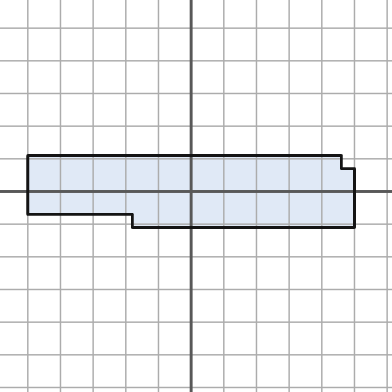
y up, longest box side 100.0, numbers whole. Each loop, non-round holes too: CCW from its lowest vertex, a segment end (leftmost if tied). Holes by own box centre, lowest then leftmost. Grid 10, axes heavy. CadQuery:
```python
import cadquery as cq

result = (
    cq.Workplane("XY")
    .moveTo(-18.0, -11.0)
    .lineTo(50.0, -11.0)
    .lineTo(50.0, 7.0)
    .lineTo(46.0, 7.0)
    .lineTo(46.0, 11.0)
    .lineTo(-50.0, 11.0)
    .lineTo(-50.0, -7.0)
    .lineTo(-18.0, -7.0)
    .close()
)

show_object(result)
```